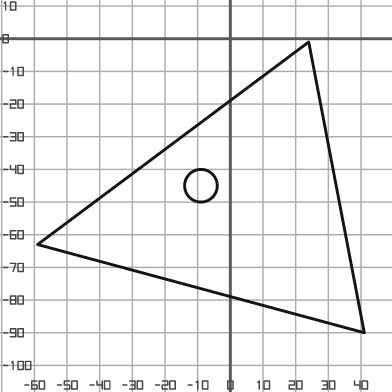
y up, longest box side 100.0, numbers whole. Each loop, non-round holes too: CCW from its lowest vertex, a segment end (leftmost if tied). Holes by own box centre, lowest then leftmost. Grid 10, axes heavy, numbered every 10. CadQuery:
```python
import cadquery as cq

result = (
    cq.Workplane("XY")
    .moveTo(41.0, -90.0)
    .lineTo(24.0, -1.0)
    .lineTo(-59.0, -63.0)
    .close()
    .moveTo(-9.0, -45.0)
    .circle(5.0)
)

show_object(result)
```